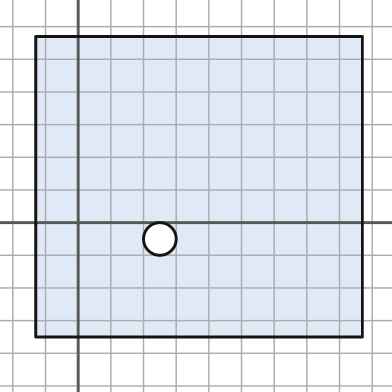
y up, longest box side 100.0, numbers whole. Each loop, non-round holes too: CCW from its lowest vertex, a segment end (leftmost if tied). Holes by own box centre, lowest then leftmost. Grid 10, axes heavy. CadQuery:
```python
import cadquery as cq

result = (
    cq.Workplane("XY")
    .moveTo(-13.0, -35.0)
    .lineTo(87.0, -35.0)
    .lineTo(87.0, 57.0)
    .lineTo(-13.0, 57.0)
    .close()
    .moveTo(25.0, -5.0)
    .circle(5.0)
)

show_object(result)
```